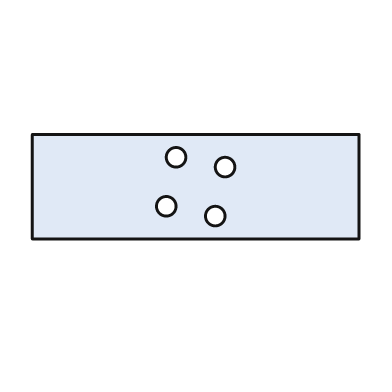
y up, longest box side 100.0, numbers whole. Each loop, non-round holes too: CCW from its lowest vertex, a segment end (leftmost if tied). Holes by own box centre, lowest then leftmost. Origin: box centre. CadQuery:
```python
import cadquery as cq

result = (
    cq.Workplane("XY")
    .moveTo(-50.0, -16.0)
    .lineTo(50.0, -16.0)
    .lineTo(50.0, 16.0)
    .lineTo(-50.0, 16.0)
    .close()
    .moveTo(6.0, -9.0)
    .circle(3.0)
    .moveTo(-9.0, -6.0)
    .circle(3.0)
    .moveTo(9.0, 6.0)
    .circle(3.0)
    .moveTo(-6.0, 9.0)
    .circle(3.0)
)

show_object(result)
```